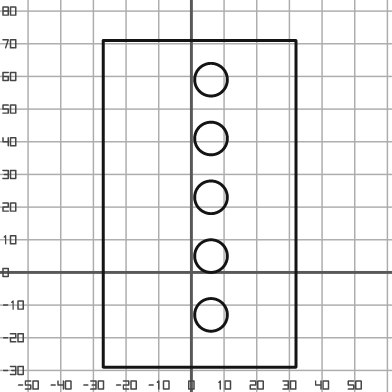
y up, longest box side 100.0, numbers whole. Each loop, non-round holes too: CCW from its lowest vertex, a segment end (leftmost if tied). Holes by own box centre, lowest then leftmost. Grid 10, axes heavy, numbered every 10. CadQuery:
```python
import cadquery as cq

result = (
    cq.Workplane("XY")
    .moveTo(-27.0, -29.0)
    .lineTo(32.0, -29.0)
    .lineTo(32.0, 71.0)
    .lineTo(-27.0, 71.0)
    .close()
    .moveTo(6.0, -13.0)
    .circle(5.0)
    .moveTo(6.0, 5.0)
    .circle(5.0)
    .moveTo(6.0, 23.0)
    .circle(5.0)
    .moveTo(6.0, 41.0)
    .circle(5.0)
    .moveTo(6.0, 59.0)
    .circle(5.0)
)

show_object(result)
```